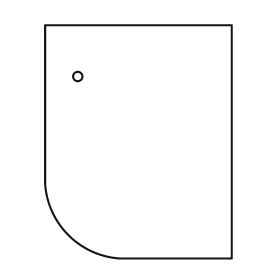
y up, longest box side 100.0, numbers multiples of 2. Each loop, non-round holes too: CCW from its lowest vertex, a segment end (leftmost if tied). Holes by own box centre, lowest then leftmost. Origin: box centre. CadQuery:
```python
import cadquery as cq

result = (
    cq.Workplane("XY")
    .moveTo(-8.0, -50.0)
    .lineTo(40.0, -50.0)
    .lineTo(40.0, 50.0)
    .lineTo(-40.0, 50.0)
    .lineTo(-40.0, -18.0)
    .threePointArc((-30.0, -40.0), (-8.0, -50.0))
    .close()
    .moveTo(-26.0, 28.0)
    .circle(2.0)
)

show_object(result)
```